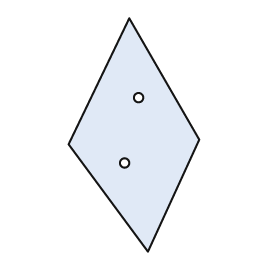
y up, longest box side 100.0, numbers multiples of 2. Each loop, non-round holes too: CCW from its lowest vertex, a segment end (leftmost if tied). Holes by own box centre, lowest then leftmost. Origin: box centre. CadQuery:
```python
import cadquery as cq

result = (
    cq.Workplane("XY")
    .moveTo(6.0, -50.0)
    .lineTo(28.0, -2.0)
    .lineTo(-2.0, 50.0)
    .lineTo(-28.0, -4.0)
    .close()
    .moveTo(-4.0, -12.0)
    .circle(2.0)
    .moveTo(2.0, 16.0)
    .circle(2.0)
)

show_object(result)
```